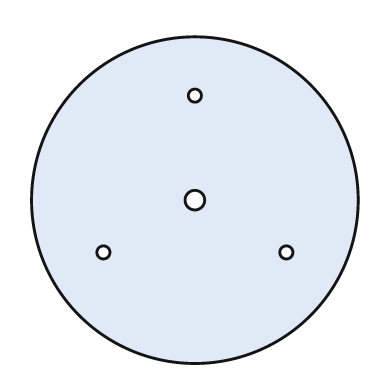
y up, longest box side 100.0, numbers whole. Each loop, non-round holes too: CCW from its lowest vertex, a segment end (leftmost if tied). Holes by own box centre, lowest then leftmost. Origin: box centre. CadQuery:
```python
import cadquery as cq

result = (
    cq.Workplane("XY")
    .moveTo(0.0, 0.0)
    .circle(50.0)
    .moveTo(-28.0, -16.0)
    .circle(2.0)
    .moveTo(28.0, -16.0)
    .circle(2.0)
    .moveTo(0.0, 0.0)
    .circle(3.0)
    .moveTo(0.0, 32.0)
    .circle(2.0)
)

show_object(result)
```